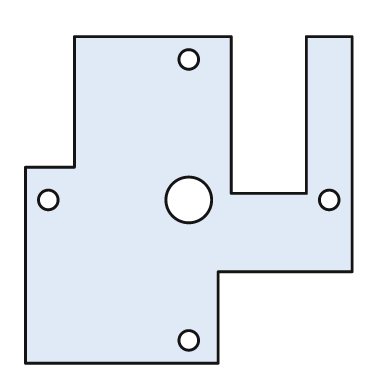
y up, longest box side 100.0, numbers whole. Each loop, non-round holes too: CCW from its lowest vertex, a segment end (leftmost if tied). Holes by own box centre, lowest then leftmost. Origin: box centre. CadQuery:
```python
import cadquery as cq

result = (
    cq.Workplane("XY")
    .moveTo(-50.0, -50.0)
    .lineTo(9.0, -50.0)
    .lineTo(9.0, -22.0)
    .lineTo(50.0, -22.0)
    .lineTo(50.0, 50.0)
    .lineTo(36.0, 50.0)
    .lineTo(36.0, 2.0)
    .lineTo(13.0, 2.0)
    .lineTo(13.0, 50.0)
    .lineTo(-35.0, 50.0)
    .lineTo(-35.0, 10.0)
    .lineTo(-50.0, 10.0)
    .close()
    .moveTo(0.0, -43.0)
    .circle(3.0)
    .moveTo(-43.0, 0.0)
    .circle(3.0)
    .moveTo(0.0, 0.0)
    .circle(7.0)
    .moveTo(43.0, 0.0)
    .circle(3.0)
    .moveTo(0.0, 43.0)
    .circle(3.0)
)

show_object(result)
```